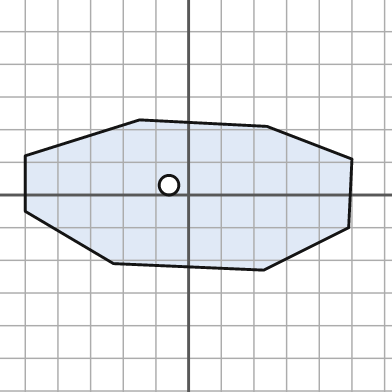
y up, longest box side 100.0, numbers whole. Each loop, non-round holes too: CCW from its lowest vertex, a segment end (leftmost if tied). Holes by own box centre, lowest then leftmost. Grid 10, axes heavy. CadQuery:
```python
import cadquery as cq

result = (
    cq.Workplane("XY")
    .moveTo(23.0, -23.0)
    .lineTo(49.0, -10.0)
    .lineTo(50.0, 11.0)
    .lineTo(24.0, 21.0)
    .lineTo(-15.0, 23.0)
    .lineTo(-50.0, 12.0)
    .lineTo(-50.0, -5.0)
    .lineTo(-23.0, -21.0)
    .close()
    .moveTo(-6.0, 3.0)
    .circle(3.0)
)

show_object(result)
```